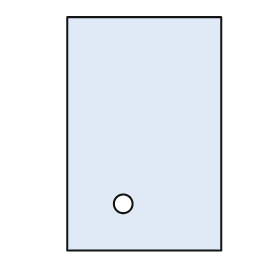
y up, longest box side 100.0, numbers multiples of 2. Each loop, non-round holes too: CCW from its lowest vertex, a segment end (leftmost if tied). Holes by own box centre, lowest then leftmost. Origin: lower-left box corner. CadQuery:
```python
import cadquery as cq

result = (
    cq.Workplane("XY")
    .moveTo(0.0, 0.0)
    .lineTo(66.0, 0.0)
    .lineTo(66.0, 100.0)
    .lineTo(0.0, 100.0)
    .close()
    .moveTo(24.0, 20.0)
    .circle(4.0)
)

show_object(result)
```